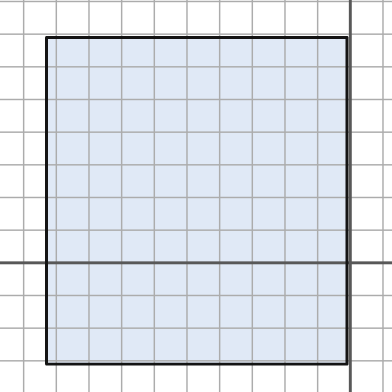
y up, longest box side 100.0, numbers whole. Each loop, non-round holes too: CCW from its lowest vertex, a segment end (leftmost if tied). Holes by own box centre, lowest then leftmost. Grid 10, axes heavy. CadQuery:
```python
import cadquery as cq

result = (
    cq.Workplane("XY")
    .moveTo(-93.0, -31.0)
    .lineTo(-1.0, -31.0)
    .lineTo(-1.0, 69.0)
    .lineTo(-93.0, 69.0)
    .close()
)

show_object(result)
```